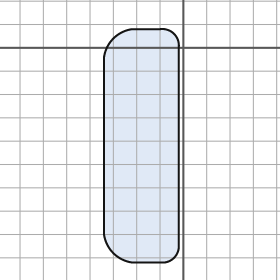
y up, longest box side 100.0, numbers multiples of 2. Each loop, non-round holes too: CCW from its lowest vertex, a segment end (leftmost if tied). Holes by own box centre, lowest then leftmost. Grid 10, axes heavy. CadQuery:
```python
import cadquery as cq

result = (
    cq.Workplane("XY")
    .moveTo(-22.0, -92.0)
    .lineTo(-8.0, -92.0)
    .threePointArc((-4.0, -90.0), (-2.0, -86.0))
    .lineTo(-2.0, 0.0)
    .threePointArc((-4.0, 6.0), (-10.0, 8.0))
    .lineTo(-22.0, 8.0)
    .threePointArc((-30.0, 4.0), (-34.0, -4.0))
    .lineTo(-34.0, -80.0)
    .threePointArc((-30.0, -88.0), (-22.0, -92.0))
    .close()
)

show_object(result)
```